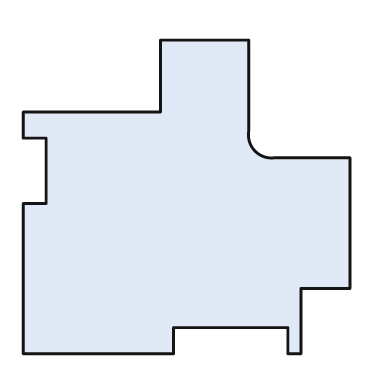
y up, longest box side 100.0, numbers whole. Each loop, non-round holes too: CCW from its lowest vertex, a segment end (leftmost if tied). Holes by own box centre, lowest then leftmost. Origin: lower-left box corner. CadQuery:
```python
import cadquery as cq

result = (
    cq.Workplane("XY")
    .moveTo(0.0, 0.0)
    .lineTo(46.0, 0.0)
    .lineTo(46.0, 8.0)
    .lineTo(81.0, 8.0)
    .lineTo(81.0, 0.0)
    .lineTo(85.0, 0.0)
    .lineTo(85.0, 20.0)
    .lineTo(100.0, 20.0)
    .lineTo(100.0, 60.0)
    .lineTo(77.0, 60.0)
    .threePointArc((71.0, 62.0), (69.0, 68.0))
    .lineTo(69.0, 96.0)
    .lineTo(42.0, 96.0)
    .lineTo(42.0, 74.0)
    .lineTo(0.0, 74.0)
    .lineTo(0.0, 66.0)
    .lineTo(7.0, 66.0)
    .lineTo(7.0, 46.0)
    .lineTo(0.0, 46.0)
    .close()
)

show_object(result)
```